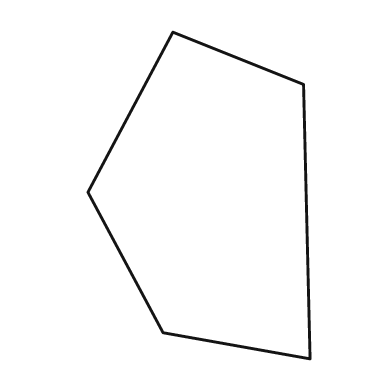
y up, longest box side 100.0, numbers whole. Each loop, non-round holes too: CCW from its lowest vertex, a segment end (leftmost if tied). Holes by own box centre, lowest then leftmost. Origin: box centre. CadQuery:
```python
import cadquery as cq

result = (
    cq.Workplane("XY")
    .moveTo(34.0, -50.0)
    .lineTo(32.0, 34.0)
    .lineTo(-8.0, 50.0)
    .lineTo(-34.0, 1.0)
    .lineTo(-11.0, -42.0)
    .close()
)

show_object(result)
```